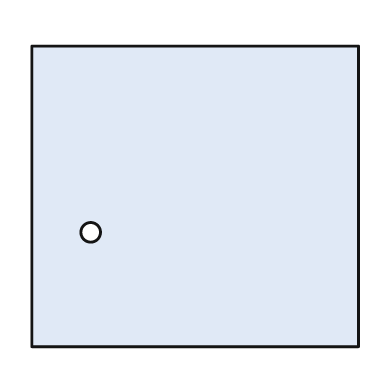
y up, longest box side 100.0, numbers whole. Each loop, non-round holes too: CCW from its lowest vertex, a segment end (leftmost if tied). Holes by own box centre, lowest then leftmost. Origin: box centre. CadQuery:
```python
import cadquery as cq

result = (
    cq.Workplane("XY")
    .moveTo(-50.0, -46.0)
    .lineTo(50.0, -46.0)
    .lineTo(50.0, 46.0)
    .lineTo(-50.0, 46.0)
    .close()
    .moveTo(-32.0, -11.0)
    .circle(3.0)
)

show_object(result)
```